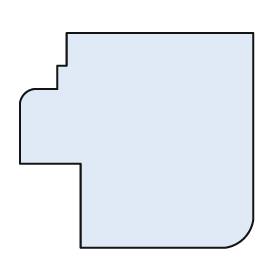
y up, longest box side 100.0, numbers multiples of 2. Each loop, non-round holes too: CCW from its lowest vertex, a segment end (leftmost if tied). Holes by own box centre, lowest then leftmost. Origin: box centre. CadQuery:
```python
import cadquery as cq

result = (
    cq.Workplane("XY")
    .moveTo(-24.0, -46.0)
    .lineTo(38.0, -46.0)
    .threePointArc((46.0, -42.0), (50.0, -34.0))
    .lineTo(50.0, 46.0)
    .lineTo(-30.0, 46.0)
    .lineTo(-30.0, 32.0)
    .lineTo(-34.0, 32.0)
    .lineTo(-34.0, 22.0)
    .lineTo(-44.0, 22.0)
    .threePointArc((-48.0, 20.0), (-50.0, 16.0))
    .lineTo(-50.0, -10.0)
    .lineTo(-24.0, -10.0)
    .close()
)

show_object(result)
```